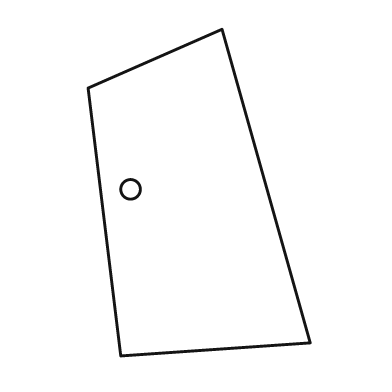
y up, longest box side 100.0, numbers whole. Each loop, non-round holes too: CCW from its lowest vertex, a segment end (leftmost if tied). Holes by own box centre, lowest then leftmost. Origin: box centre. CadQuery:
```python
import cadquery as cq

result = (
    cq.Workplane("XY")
    .moveTo(-24.0, -50.0)
    .lineTo(34.0, -46.0)
    .lineTo(7.0, 50.0)
    .lineTo(-34.0, 32.0)
    .close()
    .moveTo(-21.0, 1.0)
    .circle(3.0)
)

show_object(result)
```